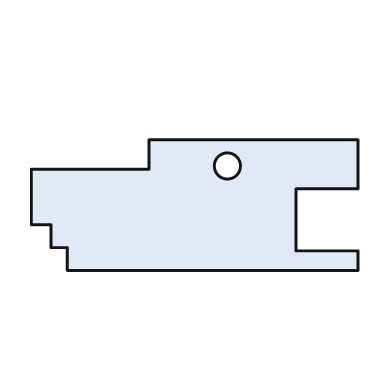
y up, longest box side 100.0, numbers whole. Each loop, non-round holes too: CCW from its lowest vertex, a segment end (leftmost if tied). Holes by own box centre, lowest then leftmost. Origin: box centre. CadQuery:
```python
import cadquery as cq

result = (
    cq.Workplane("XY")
    .moveTo(-39.0, -20.0)
    .lineTo(50.0, -20.0)
    .lineTo(50.0, -14.0)
    .lineTo(31.0, -14.0)
    .lineTo(31.0, 5.0)
    .lineTo(50.0, 5.0)
    .lineTo(50.0, 20.0)
    .lineTo(-14.0, 20.0)
    .lineTo(-14.0, 11.0)
    .lineTo(-50.0, 11.0)
    .lineTo(-50.0, -6.0)
    .lineTo(-44.0, -6.0)
    .lineTo(-44.0, -13.0)
    .lineTo(-39.0, -13.0)
    .close()
    .moveTo(10.0, 12.0)
    .circle(4.0)
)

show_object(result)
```